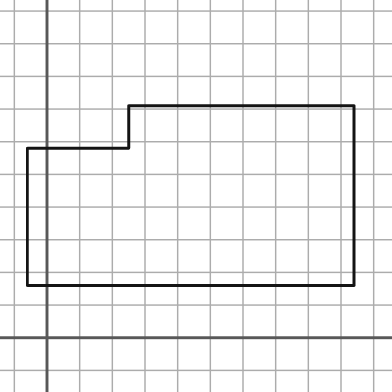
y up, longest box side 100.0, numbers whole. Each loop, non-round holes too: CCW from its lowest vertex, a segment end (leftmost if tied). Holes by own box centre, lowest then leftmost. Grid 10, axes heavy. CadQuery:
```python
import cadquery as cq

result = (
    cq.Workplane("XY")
    .moveTo(-6.0, 16.0)
    .lineTo(94.0, 16.0)
    .lineTo(94.0, 71.0)
    .lineTo(25.0, 71.0)
    .lineTo(25.0, 58.0)
    .lineTo(-6.0, 58.0)
    .close()
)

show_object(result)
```